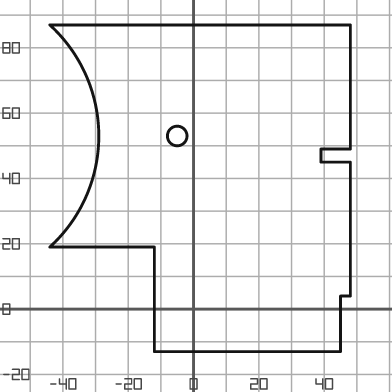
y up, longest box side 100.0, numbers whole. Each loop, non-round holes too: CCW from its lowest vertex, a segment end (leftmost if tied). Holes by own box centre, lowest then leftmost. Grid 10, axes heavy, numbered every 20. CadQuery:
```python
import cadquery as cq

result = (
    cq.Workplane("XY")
    .moveTo(-12.0, -13.0)
    .lineTo(45.0, -13.0)
    .lineTo(45.0, 4.0)
    .lineTo(48.0, 4.0)
    .lineTo(48.0, 45.0)
    .lineTo(39.0, 45.0)
    .lineTo(39.0, 49.0)
    .lineTo(48.0, 49.0)
    .lineTo(48.0, 87.0)
    .lineTo(-44.0, 87.0)
    .threePointArc((-29.0, 53.0), (-44.0, 19.0))
    .lineTo(-12.0, 19.0)
    .close()
    .moveTo(-5.0, 53.0)
    .circle(3.0)
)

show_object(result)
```